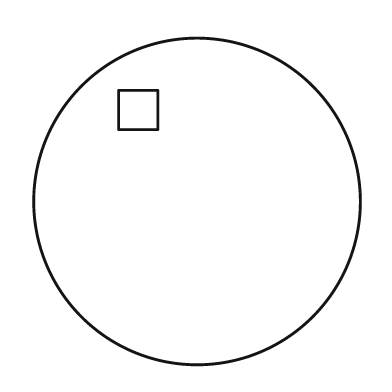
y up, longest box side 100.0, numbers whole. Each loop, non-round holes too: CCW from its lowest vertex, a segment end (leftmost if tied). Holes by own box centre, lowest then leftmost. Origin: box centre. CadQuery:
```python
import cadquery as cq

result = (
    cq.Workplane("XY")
    .moveTo(0.0, 0.0)
    .circle(50.0)
    .moveTo(-24.0, 22.0)
    .lineTo(-12.0, 22.0)
    .lineTo(-12.0, 34.0)
    .lineTo(-24.0, 34.0)
    .close()
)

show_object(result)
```